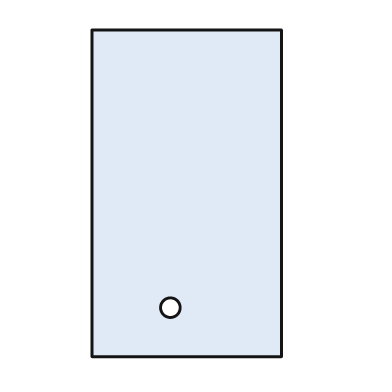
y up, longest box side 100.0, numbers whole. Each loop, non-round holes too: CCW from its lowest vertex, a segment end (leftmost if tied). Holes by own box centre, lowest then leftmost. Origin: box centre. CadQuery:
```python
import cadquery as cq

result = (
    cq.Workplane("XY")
    .moveTo(-29.0, -50.0)
    .lineTo(29.0, -50.0)
    .lineTo(29.0, 50.0)
    .lineTo(-29.0, 50.0)
    .close()
    .moveTo(-5.0, -35.0)
    .circle(3.0)
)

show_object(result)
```